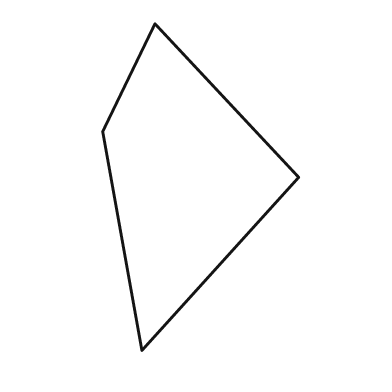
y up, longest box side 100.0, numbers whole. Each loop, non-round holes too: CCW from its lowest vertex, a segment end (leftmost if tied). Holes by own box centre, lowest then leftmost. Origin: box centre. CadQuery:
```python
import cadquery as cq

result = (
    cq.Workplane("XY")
    .moveTo(-18.0, -50.0)
    .lineTo(30.0, 3.0)
    .lineTo(-14.0, 50.0)
    .lineTo(-30.0, 17.0)
    .close()
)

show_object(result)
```